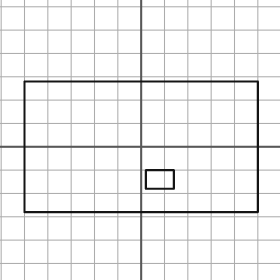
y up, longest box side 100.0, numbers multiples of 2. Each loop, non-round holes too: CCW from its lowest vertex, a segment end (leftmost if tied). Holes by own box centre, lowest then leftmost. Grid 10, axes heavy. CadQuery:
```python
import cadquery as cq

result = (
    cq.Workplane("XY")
    .moveTo(-50.0, -28.0)
    .lineTo(50.0, -28.0)
    .lineTo(50.0, 28.0)
    .lineTo(-50.0, 28.0)
    .close()
    .moveTo(2.0, -18.0)
    .lineTo(14.0, -18.0)
    .lineTo(14.0, -10.0)
    .lineTo(2.0, -10.0)
    .close()
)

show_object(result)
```